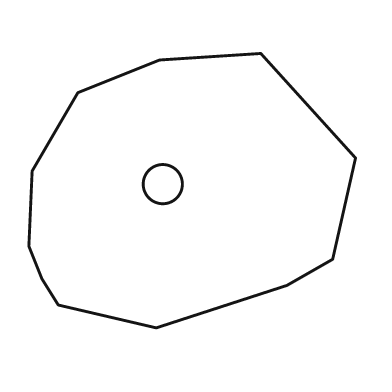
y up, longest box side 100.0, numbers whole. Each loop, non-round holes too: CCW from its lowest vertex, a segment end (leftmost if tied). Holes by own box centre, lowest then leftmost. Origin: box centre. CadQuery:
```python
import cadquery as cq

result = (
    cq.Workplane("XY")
    .moveTo(-11.0, -42.0)
    .lineTo(29.0, -29.0)
    .lineTo(43.0, -21.0)
    .lineTo(50.0, 10.0)
    .lineTo(21.0, 42.0)
    .lineTo(-10.0, 40.0)
    .lineTo(-35.0, 30.0)
    .lineTo(-49.0, 6.0)
    .lineTo(-50.0, -17.0)
    .lineTo(-46.0, -27.0)
    .lineTo(-41.0, -35.0)
    .close()
    .moveTo(-9.0, 2.0)
    .circle(6.0)
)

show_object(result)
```